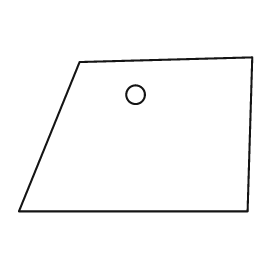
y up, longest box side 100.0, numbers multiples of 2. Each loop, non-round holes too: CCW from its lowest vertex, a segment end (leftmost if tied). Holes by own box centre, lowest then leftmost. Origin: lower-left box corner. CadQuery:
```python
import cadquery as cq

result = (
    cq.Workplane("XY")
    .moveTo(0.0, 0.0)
    .lineTo(98.0, 0.0)
    .lineTo(100.0, 66.0)
    .lineTo(26.0, 64.0)
    .close()
    .moveTo(50.0, 50.0)
    .circle(4.0)
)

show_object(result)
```